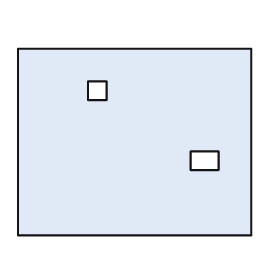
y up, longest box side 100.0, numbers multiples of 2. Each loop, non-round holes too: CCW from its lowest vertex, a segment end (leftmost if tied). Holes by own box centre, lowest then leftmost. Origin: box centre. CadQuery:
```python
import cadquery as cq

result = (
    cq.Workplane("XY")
    .moveTo(-50.0, -40.0)
    .lineTo(50.0, -40.0)
    .lineTo(50.0, 40.0)
    .lineTo(-50.0, 40.0)
    .close()
    .moveTo(24.0, -12.0)
    .lineTo(36.0, -12.0)
    .lineTo(36.0, -4.0)
    .lineTo(24.0, -4.0)
    .close()
    .moveTo(-20.0, 18.0)
    .lineTo(-12.0, 18.0)
    .lineTo(-12.0, 26.0)
    .lineTo(-20.0, 26.0)
    .close()
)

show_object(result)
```